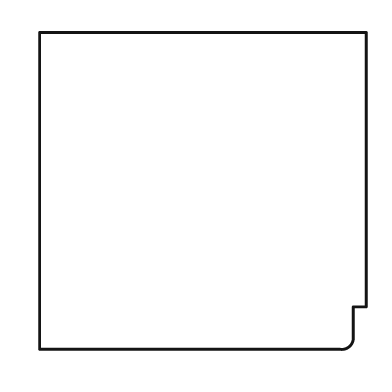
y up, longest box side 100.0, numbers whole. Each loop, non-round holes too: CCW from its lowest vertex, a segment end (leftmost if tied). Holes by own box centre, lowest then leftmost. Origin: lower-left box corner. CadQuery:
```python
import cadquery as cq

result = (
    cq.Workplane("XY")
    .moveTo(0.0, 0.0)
    .lineTo(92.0, 0.0)
    .threePointArc((95.0, 1.0), (96.0, 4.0))
    .lineTo(96.0, 13.0)
    .lineTo(100.0, 13.0)
    .lineTo(100.0, 97.0)
    .lineTo(0.0, 97.0)
    .close()
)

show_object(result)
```